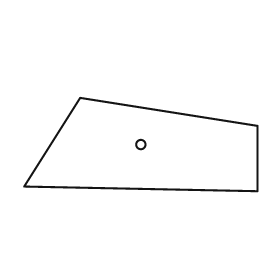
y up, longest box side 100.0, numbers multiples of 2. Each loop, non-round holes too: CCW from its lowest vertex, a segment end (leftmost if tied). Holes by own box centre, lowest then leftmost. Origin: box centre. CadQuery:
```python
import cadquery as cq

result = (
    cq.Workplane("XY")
    .moveTo(50.0, -20.0)
    .lineTo(50.0, 8.0)
    .lineTo(-26.0, 20.0)
    .lineTo(-50.0, -18.0)
    .close()
    .moveTo(0.0, 0.0)
    .circle(2.0)
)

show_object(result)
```